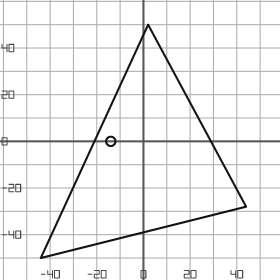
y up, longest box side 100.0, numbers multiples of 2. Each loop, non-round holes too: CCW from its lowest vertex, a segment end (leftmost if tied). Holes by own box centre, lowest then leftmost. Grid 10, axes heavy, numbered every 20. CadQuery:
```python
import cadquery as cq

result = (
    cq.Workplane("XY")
    .moveTo(-44.0, -50.0)
    .lineTo(44.0, -28.0)
    .lineTo(2.0, 50.0)
    .close()
    .moveTo(-14.0, 0.0)
    .circle(2.0)
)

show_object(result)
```